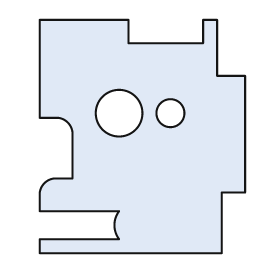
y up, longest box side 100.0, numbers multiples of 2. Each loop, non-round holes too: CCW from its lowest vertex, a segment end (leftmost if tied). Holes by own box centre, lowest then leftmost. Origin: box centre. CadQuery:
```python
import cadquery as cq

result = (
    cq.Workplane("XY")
    .moveTo(-44.0, -50.0)
    .lineTo(34.0, -50.0)
    .lineTo(34.0, -24.0)
    .lineTo(44.0, -24.0)
    .lineTo(44.0, 26.0)
    .lineTo(32.0, 26.0)
    .lineTo(32.0, 50.0)
    .lineTo(26.0, 50.0)
    .lineTo(26.0, 40.0)
    .lineTo(-6.0, 40.0)
    .lineTo(-6.0, 50.0)
    .lineTo(-44.0, 50.0)
    .lineTo(-44.0, 8.0)
    .lineTo(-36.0, 8.0)
    .threePointArc((-32.0, 6.0), (-30.0, 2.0))
    .lineTo(-30.0, -18.0)
    .lineTo(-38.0, -18.0)
    .threePointArc((-42.0, -20.0), (-44.0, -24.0))
    .lineTo(-44.0, -32.0)
    .lineTo(-10.0, -32.0)
    .threePointArc((-12.0, -38.0), (-10.0, -44.0))
    .lineTo(-44.0, -44.0)
    .close()
    .moveTo(-10.0, 10.0)
    .circle(10.0)
    .moveTo(12.0, 10.0)
    .circle(6.0)
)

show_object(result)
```